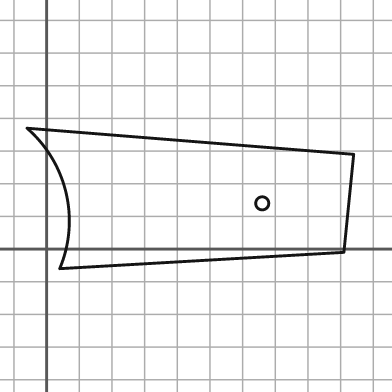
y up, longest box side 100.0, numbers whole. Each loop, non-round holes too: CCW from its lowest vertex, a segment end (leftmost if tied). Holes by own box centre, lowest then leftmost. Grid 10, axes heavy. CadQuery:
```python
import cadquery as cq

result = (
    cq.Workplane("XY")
    .moveTo(4.0, -6.0)
    .lineTo(91.0, -1.0)
    .lineTo(94.0, 29.0)
    .lineTo(-6.0, 37.0)
    .threePointArc((6.0, 17.0), (4.0, -6.0))
    .close()
    .moveTo(66.0, 14.0)
    .circle(2.0)
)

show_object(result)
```